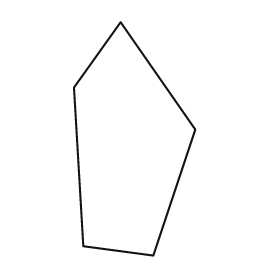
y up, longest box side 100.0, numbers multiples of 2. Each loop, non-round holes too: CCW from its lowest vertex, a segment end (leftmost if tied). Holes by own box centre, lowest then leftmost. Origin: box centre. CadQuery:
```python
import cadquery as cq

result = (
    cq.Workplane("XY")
    .moveTo(8.0, -50.0)
    .lineTo(26.0, 4.0)
    .lineTo(-6.0, 50.0)
    .lineTo(-26.0, 22.0)
    .lineTo(-22.0, -46.0)
    .close()
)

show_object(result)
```